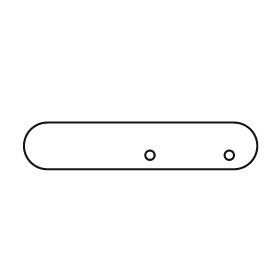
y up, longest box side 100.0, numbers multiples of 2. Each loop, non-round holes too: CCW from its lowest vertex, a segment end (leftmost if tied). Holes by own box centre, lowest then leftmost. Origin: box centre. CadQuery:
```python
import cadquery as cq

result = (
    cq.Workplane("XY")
    .moveTo(-40.0, -10.0)
    .lineTo(40.0, -10.0)
    .threePointArc((50.0, 0.0), (40.0, 10.0))
    .lineTo(-40.0, 10.0)
    .threePointArc((-50.0, 0.0), (-40.0, -10.0))
    .close()
    .moveTo(4.0, -4.0)
    .circle(2.0)
    .moveTo(38.0, -4.0)
    .circle(2.0)
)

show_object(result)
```